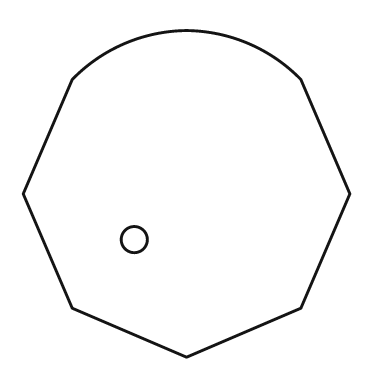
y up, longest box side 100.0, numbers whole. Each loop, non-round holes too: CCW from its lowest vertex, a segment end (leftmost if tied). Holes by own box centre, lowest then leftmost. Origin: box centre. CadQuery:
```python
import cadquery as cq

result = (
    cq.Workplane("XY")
    .moveTo(0.0, -50.0)
    .lineTo(35.0, -35.0)
    .lineTo(50.0, 0.0)
    .lineTo(35.0, 35.0)
    .threePointArc((19.0, 46.0), (0.0, 50.0))
    .threePointArc((-19.0, 46.0), (-35.0, 35.0))
    .lineTo(-50.0, 0.0)
    .lineTo(-35.0, -35.0)
    .close()
    .moveTo(-16.0, -14.0)
    .circle(4.0)
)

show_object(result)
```